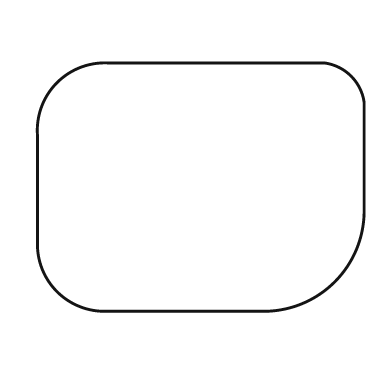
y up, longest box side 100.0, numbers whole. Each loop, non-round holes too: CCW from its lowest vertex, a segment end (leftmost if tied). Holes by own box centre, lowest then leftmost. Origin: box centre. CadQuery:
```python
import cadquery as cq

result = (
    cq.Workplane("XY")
    .moveTo(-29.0, -38.0)
    .lineTo(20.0, -38.0)
    .threePointArc((41.0, -29.0), (50.0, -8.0))
    .lineTo(50.0, 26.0)
    .threePointArc((46.0, 34.0), (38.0, 38.0))
    .lineTo(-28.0, 38.0)
    .threePointArc((-44.0, 32.0), (-50.0, 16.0))
    .lineTo(-50.0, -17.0)
    .threePointArc((-44.0, -32.0), (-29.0, -38.0))
    .close()
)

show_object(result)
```